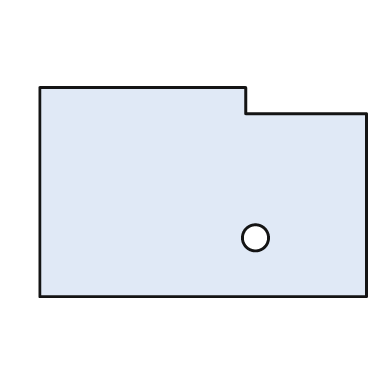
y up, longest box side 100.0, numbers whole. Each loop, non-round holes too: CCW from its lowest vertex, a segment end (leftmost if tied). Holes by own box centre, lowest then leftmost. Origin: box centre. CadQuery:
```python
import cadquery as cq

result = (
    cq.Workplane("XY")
    .moveTo(-50.0, -32.0)
    .lineTo(50.0, -32.0)
    .lineTo(50.0, 24.0)
    .lineTo(13.0, 24.0)
    .lineTo(13.0, 32.0)
    .lineTo(-50.0, 32.0)
    .close()
    .moveTo(16.0, -14.0)
    .circle(4.0)
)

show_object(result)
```